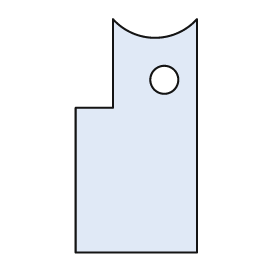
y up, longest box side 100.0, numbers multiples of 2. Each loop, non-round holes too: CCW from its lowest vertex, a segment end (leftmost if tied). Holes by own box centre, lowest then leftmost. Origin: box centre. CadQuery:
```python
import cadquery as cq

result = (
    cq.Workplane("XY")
    .moveTo(-26.0, -50.0)
    .lineTo(26.0, -50.0)
    .lineTo(26.0, 50.0)
    .threePointArc((8.0, 42.0), (-10.0, 50.0))
    .lineTo(-10.0, 12.0)
    .lineTo(-26.0, 12.0)
    .close()
    .moveTo(12.0, 24.0)
    .circle(6.0)
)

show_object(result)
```